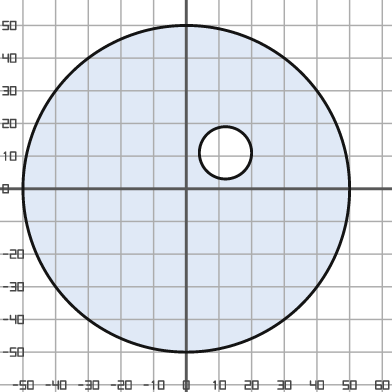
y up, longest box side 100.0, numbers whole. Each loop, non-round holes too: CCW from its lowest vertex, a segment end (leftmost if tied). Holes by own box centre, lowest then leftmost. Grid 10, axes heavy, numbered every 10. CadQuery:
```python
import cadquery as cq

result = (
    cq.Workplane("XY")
    .moveTo(0.0, 0.0)
    .circle(50.0)
    .moveTo(12.0, 11.0)
    .circle(8.0)
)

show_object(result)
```